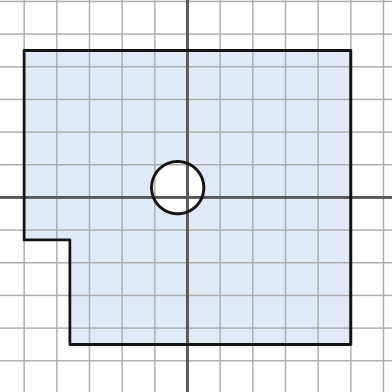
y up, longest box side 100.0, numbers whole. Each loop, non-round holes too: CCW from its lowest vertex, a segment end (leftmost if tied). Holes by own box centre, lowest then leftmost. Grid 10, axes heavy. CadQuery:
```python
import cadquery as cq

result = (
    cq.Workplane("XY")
    .moveTo(-36.0, -45.0)
    .lineTo(50.0, -45.0)
    .lineTo(50.0, 45.0)
    .lineTo(-50.0, 45.0)
    .lineTo(-50.0, -13.0)
    .lineTo(-36.0, -13.0)
    .close()
    .moveTo(-3.0, 3.0)
    .circle(8.0)
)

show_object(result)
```